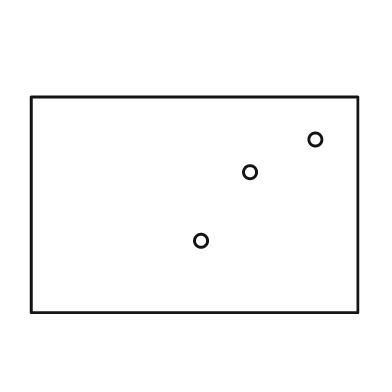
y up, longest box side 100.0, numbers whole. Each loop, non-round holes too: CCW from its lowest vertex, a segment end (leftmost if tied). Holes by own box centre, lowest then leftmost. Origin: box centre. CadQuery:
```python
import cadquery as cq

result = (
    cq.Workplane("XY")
    .moveTo(-50.0, -33.0)
    .lineTo(50.0, -33.0)
    .lineTo(50.0, 33.0)
    .lineTo(-50.0, 33.0)
    .close()
    .moveTo(2.0, -11.0)
    .circle(2.0)
    .moveTo(17.0, 10.0)
    .circle(2.0)
    .moveTo(37.0, 20.0)
    .circle(2.0)
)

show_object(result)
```